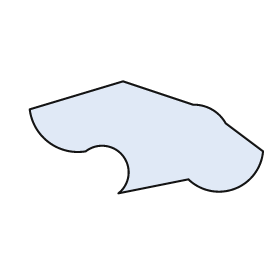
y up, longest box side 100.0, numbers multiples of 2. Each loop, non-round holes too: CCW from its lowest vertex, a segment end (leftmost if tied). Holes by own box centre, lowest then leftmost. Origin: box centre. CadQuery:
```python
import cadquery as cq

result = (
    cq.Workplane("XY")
    .moveTo(-12.0, -24.0)
    .lineTo(18.0, -18.0)
    .threePointArc((38.0, -22.0), (50.0, -6.0))
    .lineTo(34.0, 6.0)
    .threePointArc((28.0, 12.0), (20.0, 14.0))
    .lineTo(-10.0, 24.0)
    .lineTo(-50.0, 12.0)
    .threePointArc((-42.0, -2.0), (-26.0, -6.0))
    .threePointArc((-10.0, -8.0), (-12.0, -24.0))
    .close()
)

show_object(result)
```